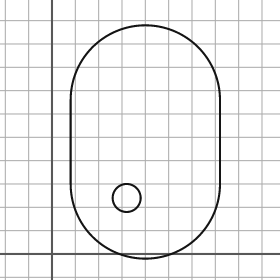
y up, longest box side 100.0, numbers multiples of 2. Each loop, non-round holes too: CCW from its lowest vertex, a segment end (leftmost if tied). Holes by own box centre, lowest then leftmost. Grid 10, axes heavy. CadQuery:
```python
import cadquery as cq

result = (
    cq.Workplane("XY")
    .moveTo(8.0, 30.0)
    .threePointArc((40.0, -2.0), (72.0, 30.0))
    .lineTo(72.0, 66.0)
    .threePointArc((40.0, 98.0), (8.0, 66.0))
    .close()
    .moveTo(32.0, 24.0)
    .circle(6.0)
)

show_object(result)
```